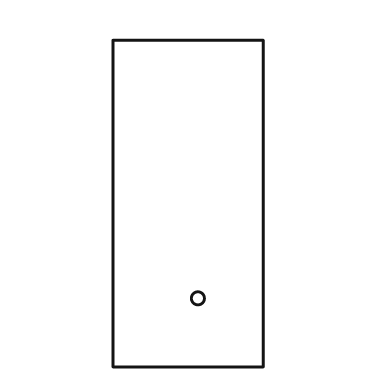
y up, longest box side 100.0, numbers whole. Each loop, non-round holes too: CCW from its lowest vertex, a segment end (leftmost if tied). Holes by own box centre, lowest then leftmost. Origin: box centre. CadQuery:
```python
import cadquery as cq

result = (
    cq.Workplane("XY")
    .moveTo(-23.0, -50.0)
    .lineTo(23.0, -50.0)
    .lineTo(23.0, 50.0)
    .lineTo(-23.0, 50.0)
    .close()
    .moveTo(3.0, -29.0)
    .circle(2.0)
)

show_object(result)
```